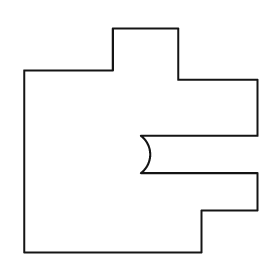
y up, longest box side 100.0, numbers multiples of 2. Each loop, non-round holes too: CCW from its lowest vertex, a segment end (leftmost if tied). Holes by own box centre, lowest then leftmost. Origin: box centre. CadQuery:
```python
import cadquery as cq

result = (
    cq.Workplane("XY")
    .moveTo(-50.0, -48.0)
    .lineTo(26.0, -48.0)
    .lineTo(26.0, -30.0)
    .lineTo(50.0, -30.0)
    .lineTo(50.0, -14.0)
    .lineTo(0.0, -14.0)
    .threePointArc((4.0, -6.0), (0.0, 2.0))
    .lineTo(50.0, 2.0)
    .lineTo(50.0, 26.0)
    .lineTo(16.0, 26.0)
    .lineTo(16.0, 48.0)
    .lineTo(-12.0, 48.0)
    .lineTo(-12.0, 30.0)
    .lineTo(-50.0, 30.0)
    .close()
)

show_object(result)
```